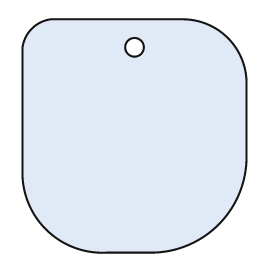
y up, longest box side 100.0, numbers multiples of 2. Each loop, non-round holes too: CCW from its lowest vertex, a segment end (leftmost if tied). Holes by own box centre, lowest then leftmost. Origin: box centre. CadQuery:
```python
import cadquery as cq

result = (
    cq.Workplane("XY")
    .moveTo(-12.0, -50.0)
    .lineTo(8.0, -50.0)
    .threePointArc((36.0, -38.0), (48.0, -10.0))
    .lineTo(48.0, 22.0)
    .threePointArc((40.0, 42.0), (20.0, 50.0))
    .lineTo(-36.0, 50.0)
    .threePointArc((-44.0, 46.0), (-48.0, 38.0))
    .lineTo(-48.0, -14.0)
    .threePointArc((-38.0, -40.0), (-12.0, -50.0))
    .close()
    .moveTo(0.0, 38.0)
    .circle(4.0)
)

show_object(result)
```